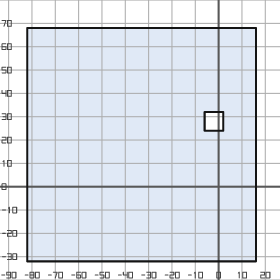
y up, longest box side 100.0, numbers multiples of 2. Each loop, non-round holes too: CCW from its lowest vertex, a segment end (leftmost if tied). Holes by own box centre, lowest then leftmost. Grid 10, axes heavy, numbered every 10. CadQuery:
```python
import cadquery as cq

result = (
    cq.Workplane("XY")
    .moveTo(-82.0, -32.0)
    .lineTo(16.0, -32.0)
    .lineTo(16.0, 68.0)
    .lineTo(-82.0, 68.0)
    .close()
    .moveTo(-6.0, 24.0)
    .lineTo(2.0, 24.0)
    .lineTo(2.0, 32.0)
    .lineTo(-6.0, 32.0)
    .close()
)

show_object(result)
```